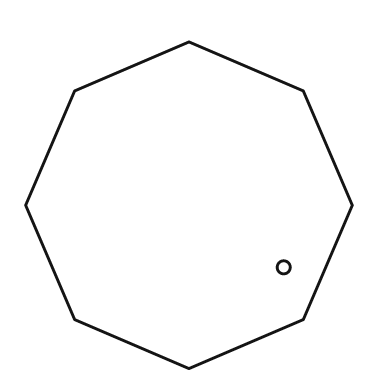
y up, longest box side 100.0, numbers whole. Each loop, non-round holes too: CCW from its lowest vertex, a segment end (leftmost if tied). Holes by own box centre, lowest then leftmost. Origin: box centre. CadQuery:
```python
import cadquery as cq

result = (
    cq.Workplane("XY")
    .moveTo(0.0, -50.0)
    .lineTo(35.0, -35.0)
    .lineTo(50.0, 0.0)
    .lineTo(35.0, 35.0)
    .lineTo(0.0, 50.0)
    .lineTo(-35.0, 35.0)
    .lineTo(-50.0, 0.0)
    .lineTo(-35.0, -35.0)
    .close()
    .moveTo(29.0, -19.0)
    .circle(2.0)
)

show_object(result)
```